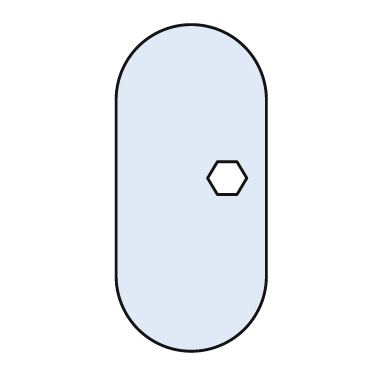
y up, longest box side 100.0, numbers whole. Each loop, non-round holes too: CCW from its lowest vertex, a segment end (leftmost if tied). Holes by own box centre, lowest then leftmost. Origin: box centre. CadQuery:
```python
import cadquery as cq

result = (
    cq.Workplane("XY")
    .moveTo(-23.0, -27.0)
    .threePointArc((0.0, -50.0), (23.0, -27.0))
    .lineTo(23.0, 27.0)
    .threePointArc((0.0, 50.0), (-23.0, 27.0))
    .close()
    .moveTo(8.0, -2.0)
    .lineTo(14.0, -2.0)
    .lineTo(17.0, 3.0)
    .lineTo(14.0, 8.0)
    .lineTo(8.0, 8.0)
    .lineTo(5.0, 3.0)
    .close()
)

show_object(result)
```